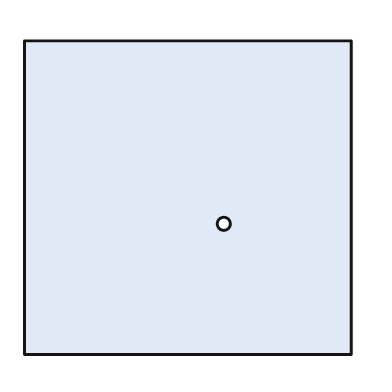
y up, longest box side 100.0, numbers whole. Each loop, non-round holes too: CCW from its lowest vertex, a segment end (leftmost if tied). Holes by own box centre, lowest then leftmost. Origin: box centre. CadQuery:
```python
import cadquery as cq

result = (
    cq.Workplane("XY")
    .moveTo(-50.0, -48.0)
    .lineTo(50.0, -48.0)
    .lineTo(50.0, 48.0)
    .lineTo(-50.0, 48.0)
    .close()
    .moveTo(11.0, -8.0)
    .circle(2.0)
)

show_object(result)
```